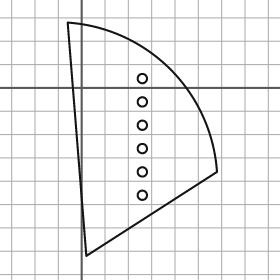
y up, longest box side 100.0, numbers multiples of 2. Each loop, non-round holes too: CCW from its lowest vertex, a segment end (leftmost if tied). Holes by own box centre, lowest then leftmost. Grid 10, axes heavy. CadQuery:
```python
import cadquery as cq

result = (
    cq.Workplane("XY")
    .moveTo(2.0, -72.0)
    .lineTo(58.0, -36.0)
    .threePointArc((38.0, 8.0), (-6.0, 28.0))
    .close()
    .moveTo(26.0, -46.0)
    .circle(2.0)
    .moveTo(26.0, -36.0)
    .circle(2.0)
    .moveTo(26.0, -26.0)
    .circle(2.0)
    .moveTo(26.0, -16.0)
    .circle(2.0)
    .moveTo(26.0, -6.0)
    .circle(2.0)
    .moveTo(26.0, 4.0)
    .circle(2.0)
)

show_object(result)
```